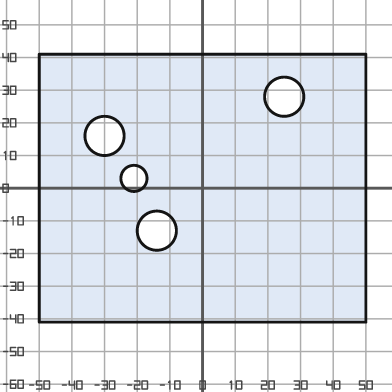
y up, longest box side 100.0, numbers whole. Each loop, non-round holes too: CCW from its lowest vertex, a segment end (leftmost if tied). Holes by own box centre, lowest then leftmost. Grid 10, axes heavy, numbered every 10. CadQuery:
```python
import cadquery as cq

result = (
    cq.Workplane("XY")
    .moveTo(-50.0, -41.0)
    .lineTo(50.0, -41.0)
    .lineTo(50.0, 41.0)
    .lineTo(-50.0, 41.0)
    .close()
    .moveTo(-14.0, -13.0)
    .circle(6.0)
    .moveTo(-21.0, 3.0)
    .circle(4.0)
    .moveTo(-30.0, 16.0)
    .circle(6.0)
    .moveTo(25.0, 28.0)
    .circle(6.0)
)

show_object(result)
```